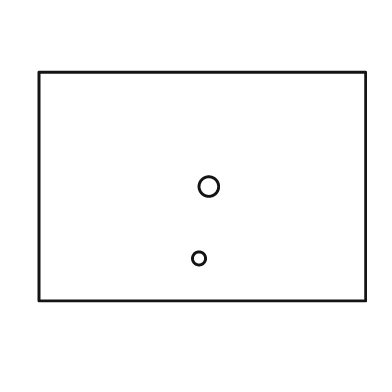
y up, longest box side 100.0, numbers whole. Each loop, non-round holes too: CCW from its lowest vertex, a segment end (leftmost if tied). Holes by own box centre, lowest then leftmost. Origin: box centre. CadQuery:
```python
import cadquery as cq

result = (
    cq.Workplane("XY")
    .moveTo(-50.0, -35.0)
    .lineTo(50.0, -35.0)
    .lineTo(50.0, 35.0)
    .lineTo(-50.0, 35.0)
    .close()
    .moveTo(-1.0, -22.0)
    .circle(2.0)
    .moveTo(2.0, 0.0)
    .circle(3.0)
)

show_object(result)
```